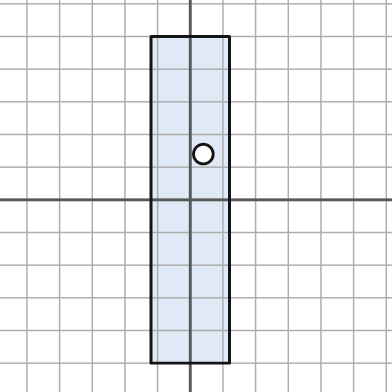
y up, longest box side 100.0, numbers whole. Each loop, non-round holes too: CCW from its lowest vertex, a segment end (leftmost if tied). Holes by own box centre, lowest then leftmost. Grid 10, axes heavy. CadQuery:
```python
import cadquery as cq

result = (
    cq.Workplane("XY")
    .moveTo(-12.0, -50.0)
    .lineTo(12.0, -50.0)
    .lineTo(12.0, 50.0)
    .lineTo(-12.0, 50.0)
    .close()
    .moveTo(4.0, 14.0)
    .circle(3.0)
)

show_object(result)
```